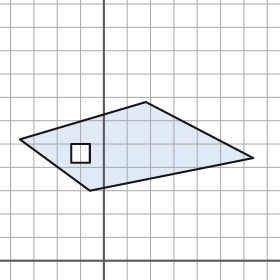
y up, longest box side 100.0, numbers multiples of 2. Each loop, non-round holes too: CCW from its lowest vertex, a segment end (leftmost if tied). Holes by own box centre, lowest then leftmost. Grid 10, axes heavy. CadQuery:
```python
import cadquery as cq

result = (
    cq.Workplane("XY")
    .moveTo(-6.0, 30.0)
    .lineTo(64.0, 44.0)
    .lineTo(18.0, 68.0)
    .lineTo(-36.0, 52.0)
    .close()
    .moveTo(-14.0, 42.0)
    .lineTo(-6.0, 42.0)
    .lineTo(-6.0, 50.0)
    .lineTo(-14.0, 50.0)
    .close()
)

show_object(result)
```